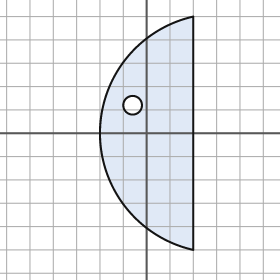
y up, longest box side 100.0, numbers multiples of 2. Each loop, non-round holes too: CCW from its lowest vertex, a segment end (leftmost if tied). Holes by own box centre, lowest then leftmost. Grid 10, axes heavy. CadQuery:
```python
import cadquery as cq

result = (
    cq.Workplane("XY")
    .moveTo(20.0, -50.0)
    .lineTo(20.0, 50.0)
    .threePointArc((-20.0, 0.0), (20.0, -50.0))
    .close()
    .moveTo(-6.0, 12.0)
    .circle(4.0)
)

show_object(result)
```